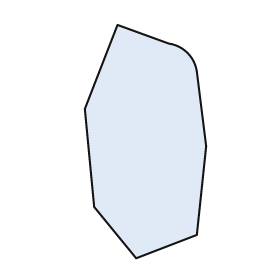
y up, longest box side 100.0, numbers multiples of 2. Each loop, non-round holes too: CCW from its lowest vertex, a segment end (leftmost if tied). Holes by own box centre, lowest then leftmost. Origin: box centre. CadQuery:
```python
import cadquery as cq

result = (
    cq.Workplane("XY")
    .moveTo(-4.0, -50.0)
    .lineTo(22.0, -40.0)
    .lineTo(26.0, -2.0)
    .lineTo(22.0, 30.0)
    .threePointArc((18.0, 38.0), (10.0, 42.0))
    .lineTo(-12.0, 50.0)
    .lineTo(-26.0, 14.0)
    .lineTo(-22.0, -28.0)
    .close()
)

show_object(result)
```